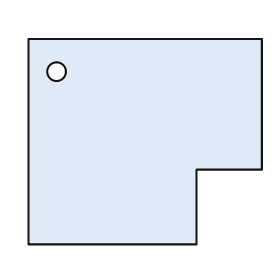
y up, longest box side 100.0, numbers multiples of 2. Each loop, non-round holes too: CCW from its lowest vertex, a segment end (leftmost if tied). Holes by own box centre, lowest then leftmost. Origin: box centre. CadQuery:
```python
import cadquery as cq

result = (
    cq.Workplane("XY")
    .moveTo(-50.0, -44.0)
    .lineTo(22.0, -44.0)
    .lineTo(22.0, -12.0)
    .lineTo(50.0, -12.0)
    .lineTo(50.0, 44.0)
    .lineTo(-50.0, 44.0)
    .close()
    .moveTo(-38.0, 30.0)
    .circle(4.0)
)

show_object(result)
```